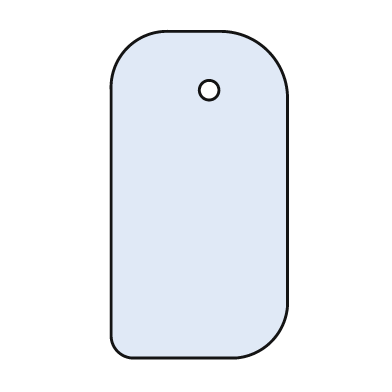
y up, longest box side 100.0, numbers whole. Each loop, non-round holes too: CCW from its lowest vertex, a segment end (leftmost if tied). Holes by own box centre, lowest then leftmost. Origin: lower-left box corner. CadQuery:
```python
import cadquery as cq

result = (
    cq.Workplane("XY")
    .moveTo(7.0, 0.0)
    .lineTo(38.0, 0.0)
    .threePointArc((49.0, 5.0), (54.0, 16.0))
    .lineTo(54.0, 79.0)
    .threePointArc((48.0, 94.0), (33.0, 100.0))
    .lineTo(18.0, 100.0)
    .threePointArc((5.0, 95.0), (0.0, 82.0))
    .lineTo(0.0, 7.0)
    .threePointArc((2.0, 2.0), (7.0, 0.0))
    .close()
    .moveTo(30.0, 82.0)
    .circle(3.0)
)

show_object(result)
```